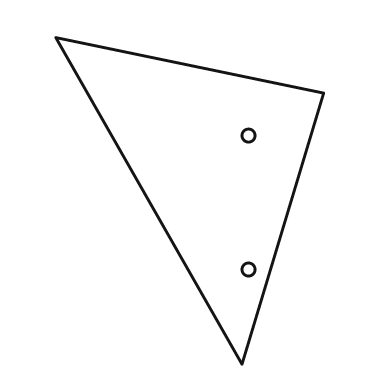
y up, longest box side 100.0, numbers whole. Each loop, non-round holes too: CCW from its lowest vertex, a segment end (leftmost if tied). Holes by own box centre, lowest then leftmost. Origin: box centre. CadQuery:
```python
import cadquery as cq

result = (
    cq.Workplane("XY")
    .moveTo(16.0, -50.0)
    .lineTo(41.0, 33.0)
    .lineTo(-41.0, 50.0)
    .close()
    .moveTo(18.0, -21.0)
    .circle(2.0)
    .moveTo(18.0, 20.0)
    .circle(2.0)
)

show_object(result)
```